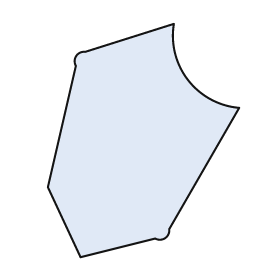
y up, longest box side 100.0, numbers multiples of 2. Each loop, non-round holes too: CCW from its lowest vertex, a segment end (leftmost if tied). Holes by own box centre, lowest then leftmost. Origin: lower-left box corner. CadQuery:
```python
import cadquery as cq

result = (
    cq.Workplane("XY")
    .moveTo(14.0, 0.0)
    .lineTo(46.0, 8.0)
    .threePointArc((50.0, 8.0), (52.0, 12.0))
    .lineTo(82.0, 64.0)
    .threePointArc((60.0, 76.0), (54.0, 100.0))
    .lineTo(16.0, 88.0)
    .threePointArc((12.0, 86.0), (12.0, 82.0))
    .lineTo(0.0, 30.0)
    .close()
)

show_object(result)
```